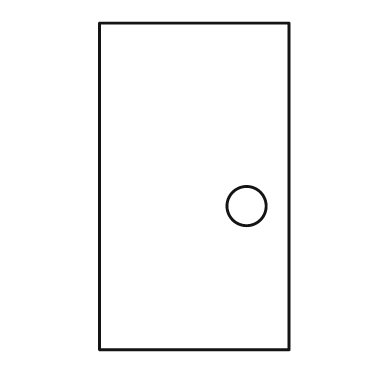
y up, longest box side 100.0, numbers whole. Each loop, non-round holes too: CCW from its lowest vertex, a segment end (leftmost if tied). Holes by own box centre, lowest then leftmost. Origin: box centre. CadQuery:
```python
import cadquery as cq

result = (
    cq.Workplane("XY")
    .moveTo(-29.0, -50.0)
    .lineTo(29.0, -50.0)
    .lineTo(29.0, 50.0)
    .lineTo(-29.0, 50.0)
    .close()
    .moveTo(16.0, -6.0)
    .circle(6.0)
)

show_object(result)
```